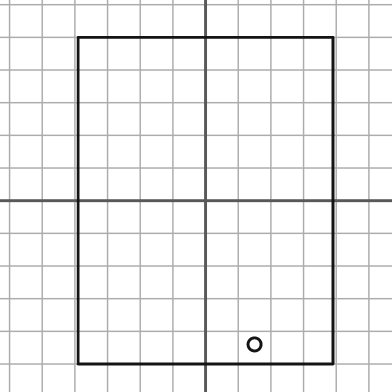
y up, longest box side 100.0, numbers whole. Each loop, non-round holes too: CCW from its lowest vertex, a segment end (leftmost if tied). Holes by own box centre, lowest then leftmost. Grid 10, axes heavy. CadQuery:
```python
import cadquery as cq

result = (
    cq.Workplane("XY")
    .moveTo(-39.0, -50.0)
    .lineTo(39.0, -50.0)
    .lineTo(39.0, 50.0)
    .lineTo(-39.0, 50.0)
    .close()
    .moveTo(15.0, -44.0)
    .circle(2.0)
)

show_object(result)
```